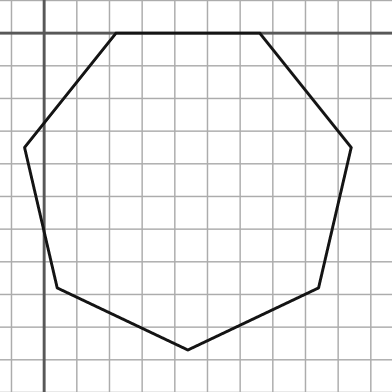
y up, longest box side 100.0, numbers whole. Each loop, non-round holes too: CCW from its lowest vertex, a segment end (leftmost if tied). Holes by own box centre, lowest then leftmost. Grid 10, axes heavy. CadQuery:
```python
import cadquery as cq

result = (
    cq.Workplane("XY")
    .moveTo(44.0, -97.0)
    .lineTo(84.0, -78.0)
    .lineTo(94.0, -35.0)
    .lineTo(66.0, 0.0)
    .lineTo(22.0, 0.0)
    .lineTo(-6.0, -35.0)
    .lineTo(4.0, -78.0)
    .close()
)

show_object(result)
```